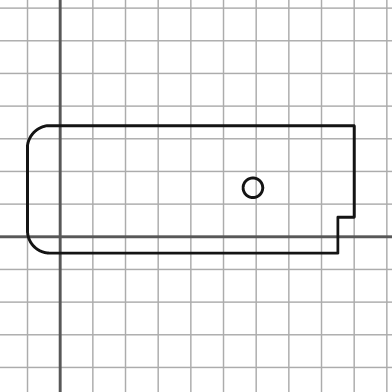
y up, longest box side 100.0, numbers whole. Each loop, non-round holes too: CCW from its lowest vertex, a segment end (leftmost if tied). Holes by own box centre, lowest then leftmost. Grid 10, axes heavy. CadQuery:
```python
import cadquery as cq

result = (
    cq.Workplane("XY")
    .moveTo(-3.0, -5.0)
    .lineTo(85.0, -5.0)
    .lineTo(85.0, 6.0)
    .lineTo(90.0, 6.0)
    .lineTo(90.0, 34.0)
    .lineTo(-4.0, 34.0)
    .threePointArc((-8.0, 32.0), (-10.0, 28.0))
    .lineTo(-10.0, 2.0)
    .threePointArc((-8.0, -3.0), (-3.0, -5.0))
    .close()
    .moveTo(59.0, 15.0)
    .circle(3.0)
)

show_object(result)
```